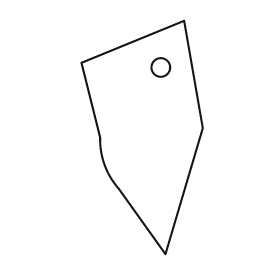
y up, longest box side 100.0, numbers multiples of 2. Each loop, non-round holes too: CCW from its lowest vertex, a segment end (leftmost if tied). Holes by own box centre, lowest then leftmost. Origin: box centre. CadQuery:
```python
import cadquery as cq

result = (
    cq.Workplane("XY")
    .moveTo(10.0, -50.0)
    .lineTo(26.0, 4.0)
    .lineTo(18.0, 50.0)
    .lineTo(-26.0, 32.0)
    .lineTo(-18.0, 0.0)
    .threePointArc((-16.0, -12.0), (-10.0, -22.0))
    .close()
    .moveTo(8.0, 30.0)
    .circle(4.0)
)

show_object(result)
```